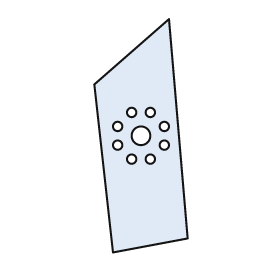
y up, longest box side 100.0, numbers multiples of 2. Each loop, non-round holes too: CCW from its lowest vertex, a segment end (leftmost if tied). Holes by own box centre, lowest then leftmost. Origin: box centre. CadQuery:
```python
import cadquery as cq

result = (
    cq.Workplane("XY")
    .moveTo(-12.0, -50.0)
    .lineTo(20.0, -44.0)
    .lineTo(12.0, 50.0)
    .lineTo(-20.0, 22.0)
    .close()
    .moveTo(-4.0, -10.0)
    .circle(2.0)
    .moveTo(4.0, -10.0)
    .circle(2.0)
    .moveTo(-10.0, -4.0)
    .circle(2.0)
    .moveTo(10.0, -4.0)
    .circle(2.0)
    .moveTo(0.0, 0.0)
    .circle(4.0)
    .moveTo(-10.0, 4.0)
    .circle(2.0)
    .moveTo(10.0, 4.0)
    .circle(2.0)
    .moveTo(-4.0, 10.0)
    .circle(2.0)
    .moveTo(4.0, 10.0)
    .circle(2.0)
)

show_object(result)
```